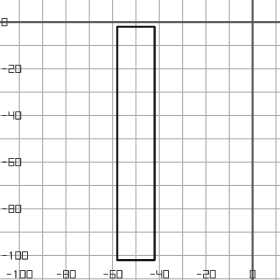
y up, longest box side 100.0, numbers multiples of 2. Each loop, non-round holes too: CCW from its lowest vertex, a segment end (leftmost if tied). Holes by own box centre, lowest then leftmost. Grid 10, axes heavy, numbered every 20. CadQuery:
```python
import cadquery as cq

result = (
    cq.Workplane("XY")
    .moveTo(-58.0, -102.0)
    .lineTo(-42.0, -102.0)
    .lineTo(-42.0, -2.0)
    .lineTo(-58.0, -2.0)
    .close()
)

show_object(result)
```